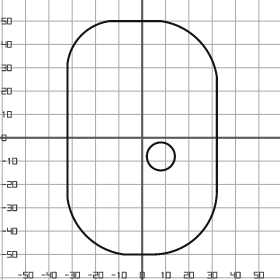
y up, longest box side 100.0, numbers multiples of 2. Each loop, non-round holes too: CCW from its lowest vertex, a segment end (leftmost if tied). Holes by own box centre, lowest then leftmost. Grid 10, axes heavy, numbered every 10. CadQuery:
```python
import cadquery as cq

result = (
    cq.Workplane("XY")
    .moveTo(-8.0, -50.0)
    .lineTo(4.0, -50.0)
    .threePointArc((24.0, -42.0), (32.0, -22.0))
    .lineTo(32.0, 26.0)
    .threePointArc((24.0, 42.0), (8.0, 50.0))
    .lineTo(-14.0, 50.0)
    .threePointArc((-26.0, 44.0), (-32.0, 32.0))
    .lineTo(-32.0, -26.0)
    .threePointArc((-24.0, -42.0), (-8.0, -50.0))
    .close()
    .moveTo(8.0, -8.0)
    .circle(6.0)
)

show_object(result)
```